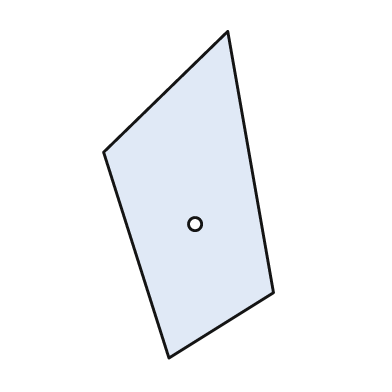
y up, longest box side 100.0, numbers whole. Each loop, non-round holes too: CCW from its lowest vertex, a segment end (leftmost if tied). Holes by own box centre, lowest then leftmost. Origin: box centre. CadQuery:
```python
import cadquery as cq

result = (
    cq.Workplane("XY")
    .moveTo(-6.0, -50.0)
    .lineTo(26.0, -30.0)
    .lineTo(12.0, 50.0)
    .lineTo(-26.0, 13.0)
    .close()
    .moveTo(2.0, -9.0)
    .circle(2.0)
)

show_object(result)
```